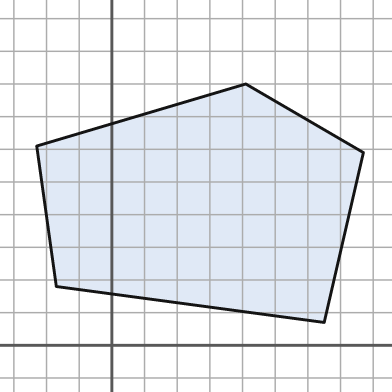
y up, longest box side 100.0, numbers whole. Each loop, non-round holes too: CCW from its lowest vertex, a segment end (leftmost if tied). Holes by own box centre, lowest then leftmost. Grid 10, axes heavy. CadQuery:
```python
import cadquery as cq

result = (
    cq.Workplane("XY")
    .moveTo(65.0, 7.0)
    .lineTo(77.0, 59.0)
    .lineTo(41.0, 80.0)
    .lineTo(-23.0, 61.0)
    .lineTo(-17.0, 18.0)
    .close()
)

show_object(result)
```